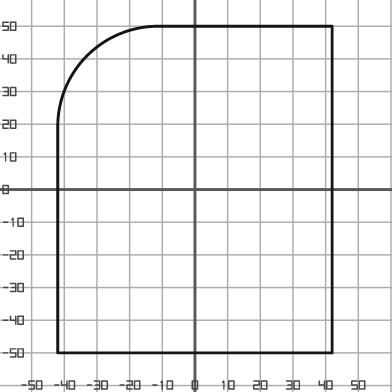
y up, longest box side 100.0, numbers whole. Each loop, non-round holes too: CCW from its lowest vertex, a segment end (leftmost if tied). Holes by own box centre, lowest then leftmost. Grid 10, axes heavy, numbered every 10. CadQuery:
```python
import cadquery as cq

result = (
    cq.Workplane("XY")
    .moveTo(-42.0, -50.0)
    .lineTo(42.0, -50.0)
    .lineTo(42.0, 50.0)
    .lineTo(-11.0, 50.0)
    .threePointArc((-33.0, 41.0), (-42.0, 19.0))
    .close()
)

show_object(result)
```